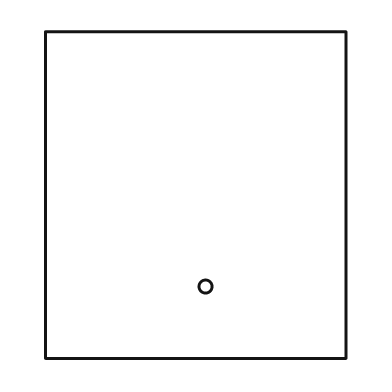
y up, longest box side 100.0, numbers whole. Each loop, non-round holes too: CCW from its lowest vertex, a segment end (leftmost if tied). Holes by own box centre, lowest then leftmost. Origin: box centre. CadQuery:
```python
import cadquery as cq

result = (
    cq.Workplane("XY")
    .moveTo(-46.0, -50.0)
    .lineTo(46.0, -50.0)
    .lineTo(46.0, 50.0)
    .lineTo(-46.0, 50.0)
    .close()
    .moveTo(3.0, -28.0)
    .circle(2.0)
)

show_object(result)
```